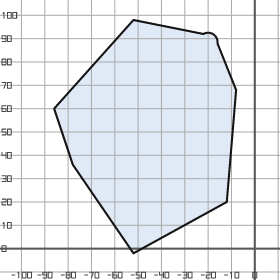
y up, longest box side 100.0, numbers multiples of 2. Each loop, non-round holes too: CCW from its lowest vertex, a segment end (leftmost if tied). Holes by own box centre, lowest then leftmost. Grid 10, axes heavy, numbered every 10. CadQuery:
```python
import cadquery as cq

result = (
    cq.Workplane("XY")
    .moveTo(-52.0, -2.0)
    .lineTo(-12.0, 20.0)
    .lineTo(-8.0, 68.0)
    .lineTo(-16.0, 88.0)
    .threePointArc((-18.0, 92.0), (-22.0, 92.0))
    .lineTo(-52.0, 98.0)
    .lineTo(-86.0, 60.0)
    .lineTo(-78.0, 36.0)
    .close()
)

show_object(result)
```